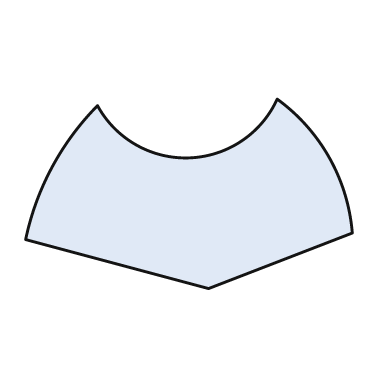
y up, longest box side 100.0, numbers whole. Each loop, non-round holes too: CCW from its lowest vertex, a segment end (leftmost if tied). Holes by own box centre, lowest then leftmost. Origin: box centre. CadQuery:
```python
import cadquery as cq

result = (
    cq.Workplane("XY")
    .moveTo(6.0, -29.0)
    .lineTo(50.0, -12.0)
    .threePointArc((43.0, 11.0), (27.0, 29.0))
    .threePointArc((0.0, 11.0), (-28.0, 27.0))
    .threePointArc((-42.0, 8.0), (-50.0, -14.0))
    .close()
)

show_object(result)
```